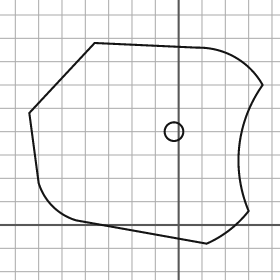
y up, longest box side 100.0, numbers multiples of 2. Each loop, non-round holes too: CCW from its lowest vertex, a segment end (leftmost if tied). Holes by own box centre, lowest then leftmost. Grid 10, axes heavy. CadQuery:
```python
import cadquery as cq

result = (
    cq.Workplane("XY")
    .moveTo(12.0, -8.0)
    .threePointArc((22.0, -2.0), (30.0, 6.0))
    .threePointArc((26.0, 34.0), (36.0, 60.0))
    .threePointArc((24.0, 72.0), (8.0, 76.0))
    .lineTo(-36.0, 78.0)
    .lineTo(-64.0, 48.0)
    .lineTo(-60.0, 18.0)
    .threePointArc((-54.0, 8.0), (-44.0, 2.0))
    .close()
    .moveTo(-2.0, 40.0)
    .circle(4.0)
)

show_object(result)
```